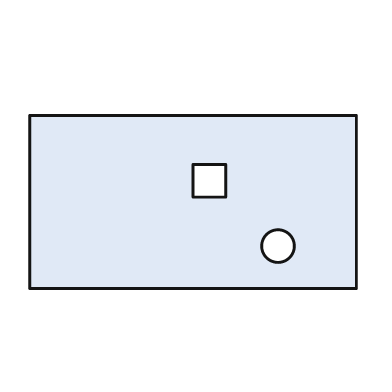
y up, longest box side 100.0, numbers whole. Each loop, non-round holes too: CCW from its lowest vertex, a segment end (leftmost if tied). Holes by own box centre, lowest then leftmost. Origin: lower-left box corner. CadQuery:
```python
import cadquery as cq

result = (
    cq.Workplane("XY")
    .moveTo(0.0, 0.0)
    .lineTo(100.0, 0.0)
    .lineTo(100.0, 53.0)
    .lineTo(0.0, 53.0)
    .close()
    .moveTo(76.0, 13.0)
    .circle(5.0)
    .moveTo(50.0, 28.0)
    .lineTo(60.0, 28.0)
    .lineTo(60.0, 38.0)
    .lineTo(50.0, 38.0)
    .close()
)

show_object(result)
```